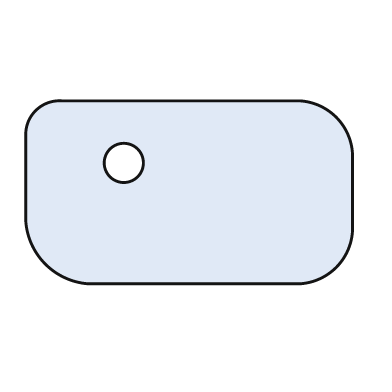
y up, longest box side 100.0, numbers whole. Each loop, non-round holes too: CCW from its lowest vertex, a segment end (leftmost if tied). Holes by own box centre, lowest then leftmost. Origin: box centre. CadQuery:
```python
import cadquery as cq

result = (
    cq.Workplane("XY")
    .moveTo(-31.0, -28.0)
    .lineTo(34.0, -28.0)
    .threePointArc((45.0, -23.0), (50.0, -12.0))
    .lineTo(50.0, 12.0)
    .threePointArc((45.0, 23.0), (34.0, 28.0))
    .lineTo(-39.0, 28.0)
    .threePointArc((-47.0, 25.0), (-50.0, 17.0))
    .lineTo(-50.0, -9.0)
    .threePointArc((-44.0, -22.0), (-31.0, -28.0))
    .close()
    .moveTo(-20.0, 9.0)
    .circle(6.0)
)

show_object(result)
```